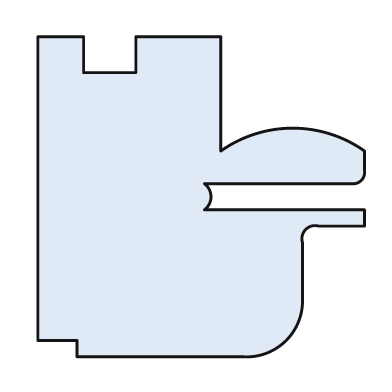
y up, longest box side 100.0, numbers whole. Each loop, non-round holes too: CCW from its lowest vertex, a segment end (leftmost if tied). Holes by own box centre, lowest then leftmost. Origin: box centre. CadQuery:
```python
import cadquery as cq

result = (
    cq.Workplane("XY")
    .moveTo(-38.0, -49.0)
    .lineTo(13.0, -49.0)
    .threePointArc((26.0, -44.0), (31.0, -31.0))
    .lineTo(31.0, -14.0)
    .threePointArc((32.0, -10.0), (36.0, -9.0))
    .lineTo(50.0, -9.0)
    .lineTo(50.0, -4.0)
    .lineTo(1.0, -4.0)
    .threePointArc((3.0, 0.0), (1.0, 4.0))
    .lineTo(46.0, 4.0)
    .threePointArc((49.0, 5.0), (50.0, 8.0))
    .lineTo(50.0, 14.0)
    .threePointArc((28.0, 21.0), (6.0, 14.0))
    .lineTo(6.0, 49.0)
    .lineTo(-20.0, 49.0)
    .lineTo(-20.0, 38.0)
    .lineTo(-36.0, 38.0)
    .lineTo(-36.0, 49.0)
    .lineTo(-50.0, 49.0)
    .lineTo(-50.0, -44.0)
    .lineTo(-38.0, -44.0)
    .close()
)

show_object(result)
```